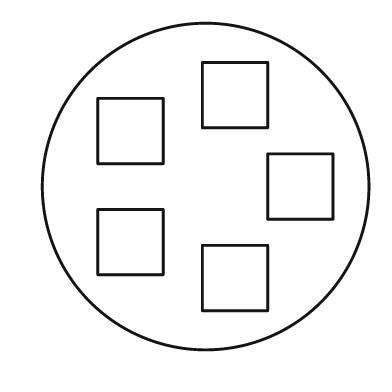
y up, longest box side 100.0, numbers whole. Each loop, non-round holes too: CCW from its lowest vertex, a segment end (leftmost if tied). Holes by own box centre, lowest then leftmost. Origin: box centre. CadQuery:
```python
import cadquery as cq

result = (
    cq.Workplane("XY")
    .moveTo(0.0, 0.0)
    .circle(50.0)
    .moveTo(-1.0, -38.0)
    .lineTo(19.0, -38.0)
    .lineTo(19.0, -18.0)
    .lineTo(-1.0, -18.0)
    .close()
    .moveTo(-33.0, -27.0)
    .lineTo(-13.0, -27.0)
    .lineTo(-13.0, -7.0)
    .lineTo(-33.0, -7.0)
    .close()
    .moveTo(19.0, -10.0)
    .lineTo(39.0, -10.0)
    .lineTo(39.0, 10.0)
    .lineTo(19.0, 10.0)
    .close()
    .moveTo(-33.0, 7.0)
    .lineTo(-13.0, 7.0)
    .lineTo(-13.0, 27.0)
    .lineTo(-33.0, 27.0)
    .close()
    .moveTo(-1.0, 18.0)
    .lineTo(19.0, 18.0)
    .lineTo(19.0, 38.0)
    .lineTo(-1.0, 38.0)
    .close()
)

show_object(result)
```